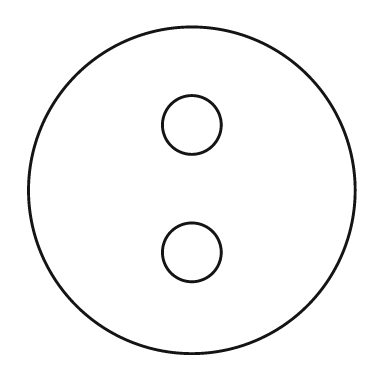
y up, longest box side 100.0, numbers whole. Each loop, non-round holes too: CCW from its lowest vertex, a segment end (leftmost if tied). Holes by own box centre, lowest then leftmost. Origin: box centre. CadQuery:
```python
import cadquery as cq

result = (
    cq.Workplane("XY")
    .moveTo(0.0, 0.0)
    .circle(50.0)
    .moveTo(0.0, -19.0)
    .circle(9.0)
    .moveTo(0.0, 20.0)
    .circle(9.0)
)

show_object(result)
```